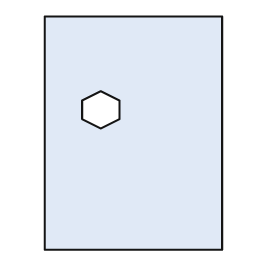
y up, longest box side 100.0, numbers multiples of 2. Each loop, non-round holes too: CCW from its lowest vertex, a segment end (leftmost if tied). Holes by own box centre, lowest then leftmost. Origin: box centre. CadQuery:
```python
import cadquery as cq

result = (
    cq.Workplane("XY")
    .moveTo(-38.0, -50.0)
    .lineTo(38.0, -50.0)
    .lineTo(38.0, 50.0)
    .lineTo(-38.0, 50.0)
    .close()
    .moveTo(-14.0, 2.0)
    .lineTo(-6.0, 6.0)
    .lineTo(-6.0, 14.0)
    .lineTo(-14.0, 18.0)
    .lineTo(-22.0, 14.0)
    .lineTo(-22.0, 6.0)
    .close()
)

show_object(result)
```